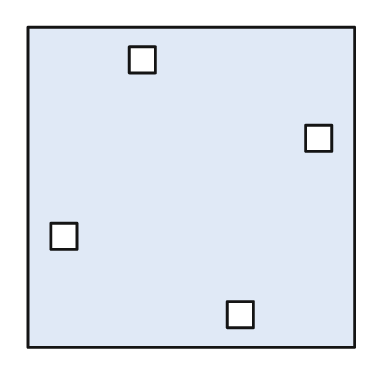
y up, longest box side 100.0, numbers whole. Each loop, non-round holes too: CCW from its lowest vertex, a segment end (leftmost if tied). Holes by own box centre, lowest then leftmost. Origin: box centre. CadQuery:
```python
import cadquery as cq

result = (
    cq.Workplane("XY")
    .moveTo(-50.0, -49.0)
    .lineTo(50.0, -49.0)
    .lineTo(50.0, 49.0)
    .lineTo(-50.0, 49.0)
    .close()
    .moveTo(11.0, -43.0)
    .lineTo(19.0, -43.0)
    .lineTo(19.0, -35.0)
    .lineTo(11.0, -35.0)
    .close()
    .moveTo(-43.0, -19.0)
    .lineTo(-35.0, -19.0)
    .lineTo(-35.0, -11.0)
    .lineTo(-43.0, -11.0)
    .close()
    .moveTo(35.0, 11.0)
    .lineTo(43.0, 11.0)
    .lineTo(43.0, 19.0)
    .lineTo(35.0, 19.0)
    .close()
    .moveTo(-19.0, 35.0)
    .lineTo(-11.0, 35.0)
    .lineTo(-11.0, 43.0)
    .lineTo(-19.0, 43.0)
    .close()
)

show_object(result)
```